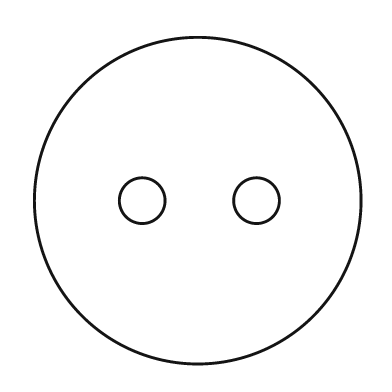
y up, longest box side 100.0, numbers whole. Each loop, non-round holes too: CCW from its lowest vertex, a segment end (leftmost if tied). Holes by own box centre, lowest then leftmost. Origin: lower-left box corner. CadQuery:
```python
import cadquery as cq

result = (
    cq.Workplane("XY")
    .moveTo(50.0, 50.0)
    .circle(50.0)
    .moveTo(33.0, 50.0)
    .circle(7.0)
    .moveTo(68.0, 50.0)
    .circle(7.0)
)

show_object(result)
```